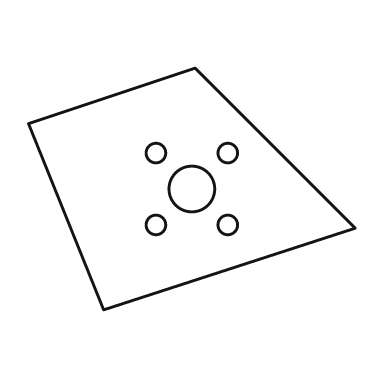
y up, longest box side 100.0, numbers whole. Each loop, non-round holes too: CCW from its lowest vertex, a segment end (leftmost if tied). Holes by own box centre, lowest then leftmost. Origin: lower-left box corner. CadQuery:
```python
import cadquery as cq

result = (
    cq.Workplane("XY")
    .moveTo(23.0, 0.0)
    .lineTo(100.0, 25.0)
    .lineTo(51.0, 74.0)
    .lineTo(0.0, 57.0)
    .close()
    .moveTo(39.0, 26.0)
    .circle(3.0)
    .moveTo(61.0, 26.0)
    .circle(3.0)
    .moveTo(50.0, 37.0)
    .circle(7.0)
    .moveTo(39.0, 48.0)
    .circle(3.0)
    .moveTo(61.0, 48.0)
    .circle(3.0)
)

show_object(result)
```